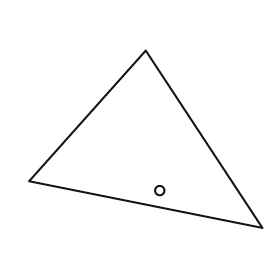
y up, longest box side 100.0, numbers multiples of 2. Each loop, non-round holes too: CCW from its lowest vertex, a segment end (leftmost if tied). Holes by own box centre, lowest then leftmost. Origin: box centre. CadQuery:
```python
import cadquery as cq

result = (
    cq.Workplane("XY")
    .moveTo(50.0, -38.0)
    .lineTo(0.0, 38.0)
    .lineTo(-50.0, -18.0)
    .close()
    .moveTo(6.0, -22.0)
    .circle(2.0)
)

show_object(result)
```